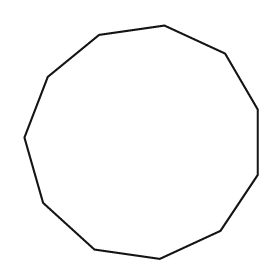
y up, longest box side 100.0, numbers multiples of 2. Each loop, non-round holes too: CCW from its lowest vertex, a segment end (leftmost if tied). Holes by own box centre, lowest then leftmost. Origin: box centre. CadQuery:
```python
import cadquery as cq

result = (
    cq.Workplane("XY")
    .moveTo(8.0, -50.0)
    .lineTo(34.0, -38.0)
    .lineTo(50.0, -14.0)
    .lineTo(50.0, 14.0)
    .lineTo(36.0, 38.0)
    .lineTo(10.0, 50.0)
    .lineTo(-18.0, 46.0)
    .lineTo(-40.0, 28.0)
    .lineTo(-50.0, 2.0)
    .lineTo(-42.0, -26.0)
    .lineTo(-20.0, -46.0)
    .close()
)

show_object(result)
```